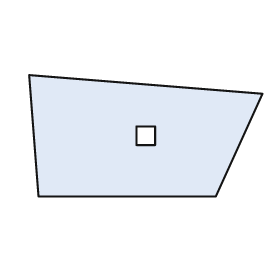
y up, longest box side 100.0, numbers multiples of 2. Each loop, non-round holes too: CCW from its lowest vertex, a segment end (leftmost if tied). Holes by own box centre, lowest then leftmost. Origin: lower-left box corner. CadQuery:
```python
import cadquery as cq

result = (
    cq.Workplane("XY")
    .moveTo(4.0, 0.0)
    .lineTo(80.0, 0.0)
    .lineTo(100.0, 44.0)
    .lineTo(0.0, 52.0)
    .close()
    .moveTo(46.0, 22.0)
    .lineTo(54.0, 22.0)
    .lineTo(54.0, 30.0)
    .lineTo(46.0, 30.0)
    .close()
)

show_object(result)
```